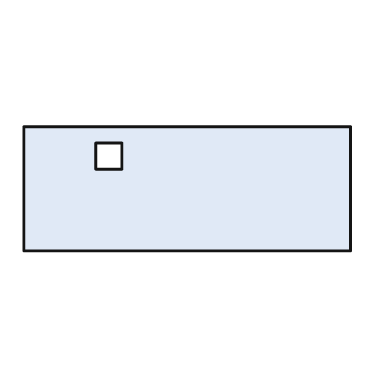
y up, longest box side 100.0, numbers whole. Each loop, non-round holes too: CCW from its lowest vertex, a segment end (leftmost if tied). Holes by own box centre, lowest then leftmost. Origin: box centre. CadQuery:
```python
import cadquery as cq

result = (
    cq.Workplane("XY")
    .moveTo(-50.0, -19.0)
    .lineTo(50.0, -19.0)
    .lineTo(50.0, 19.0)
    .lineTo(-50.0, 19.0)
    .close()
    .moveTo(-28.0, 6.0)
    .lineTo(-20.0, 6.0)
    .lineTo(-20.0, 14.0)
    .lineTo(-28.0, 14.0)
    .close()
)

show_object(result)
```